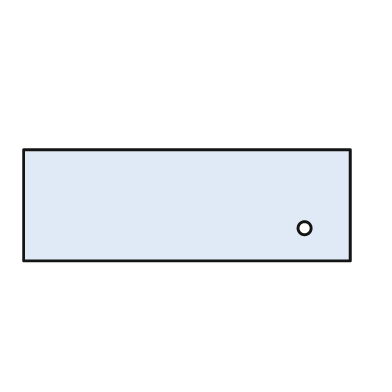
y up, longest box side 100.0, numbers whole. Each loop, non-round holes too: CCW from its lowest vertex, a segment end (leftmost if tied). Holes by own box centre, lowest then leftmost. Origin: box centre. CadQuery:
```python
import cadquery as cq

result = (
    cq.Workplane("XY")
    .moveTo(-50.0, -17.0)
    .lineTo(50.0, -17.0)
    .lineTo(50.0, 17.0)
    .lineTo(-50.0, 17.0)
    .close()
    .moveTo(36.0, -7.0)
    .circle(2.0)
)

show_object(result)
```